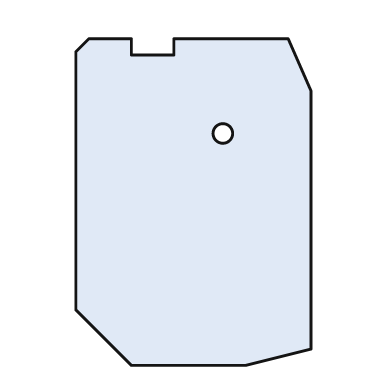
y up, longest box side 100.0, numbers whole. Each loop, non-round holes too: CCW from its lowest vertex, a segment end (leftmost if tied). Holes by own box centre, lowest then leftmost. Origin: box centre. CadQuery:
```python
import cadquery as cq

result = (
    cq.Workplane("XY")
    .moveTo(-19.0, -50.0)
    .lineTo(16.0, -50.0)
    .lineTo(36.0, -45.0)
    .lineTo(36.0, 34.0)
    .lineTo(29.0, 50.0)
    .lineTo(-6.0, 50.0)
    .lineTo(-6.0, 45.0)
    .lineTo(-19.0, 45.0)
    .lineTo(-19.0, 50.0)
    .lineTo(-32.0, 50.0)
    .lineTo(-36.0, 46.0)
    .lineTo(-36.0, -33.0)
    .close()
    .moveTo(9.0, 21.0)
    .circle(3.0)
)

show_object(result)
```